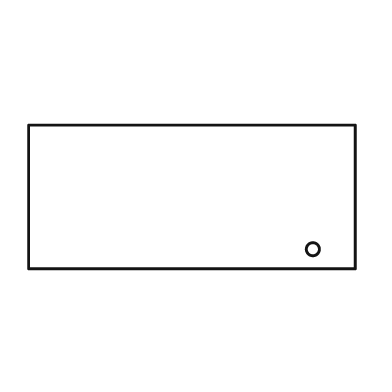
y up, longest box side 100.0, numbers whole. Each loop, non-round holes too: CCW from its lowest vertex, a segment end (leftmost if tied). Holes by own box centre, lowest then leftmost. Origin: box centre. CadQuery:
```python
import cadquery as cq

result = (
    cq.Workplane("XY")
    .moveTo(-50.0, -22.0)
    .lineTo(50.0, -22.0)
    .lineTo(50.0, 22.0)
    .lineTo(-50.0, 22.0)
    .close()
    .moveTo(37.0, -16.0)
    .circle(2.0)
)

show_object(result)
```